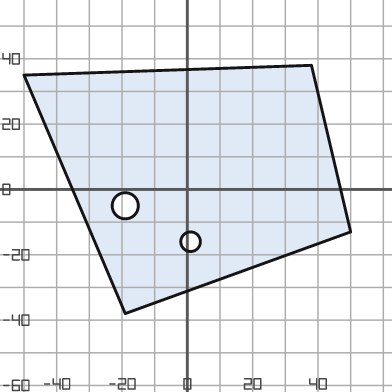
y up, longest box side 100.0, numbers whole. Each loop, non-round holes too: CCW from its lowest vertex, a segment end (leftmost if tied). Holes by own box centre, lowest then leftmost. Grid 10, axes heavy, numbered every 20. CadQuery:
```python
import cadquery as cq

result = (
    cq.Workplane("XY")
    .moveTo(-19.0, -38.0)
    .lineTo(50.0, -13.0)
    .lineTo(38.0, 38.0)
    .lineTo(-50.0, 35.0)
    .close()
    .moveTo(1.0, -16.0)
    .circle(3.0)
    .moveTo(-19.0, -5.0)
    .circle(4.0)
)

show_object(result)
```